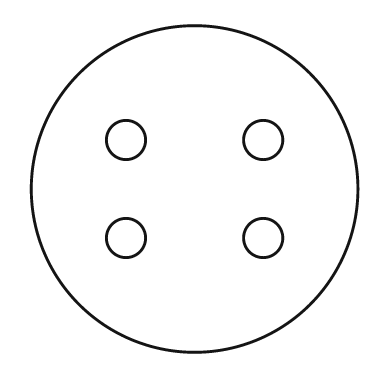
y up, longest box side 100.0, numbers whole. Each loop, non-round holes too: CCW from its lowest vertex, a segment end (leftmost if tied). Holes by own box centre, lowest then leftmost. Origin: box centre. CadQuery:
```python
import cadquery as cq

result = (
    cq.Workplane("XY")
    .moveTo(0.0, 0.0)
    .circle(50.0)
    .moveTo(-21.0, -15.0)
    .circle(6.0)
    .moveTo(21.0, -15.0)
    .circle(6.0)
    .moveTo(-21.0, 15.0)
    .circle(6.0)
    .moveTo(21.0, 15.0)
    .circle(6.0)
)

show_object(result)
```